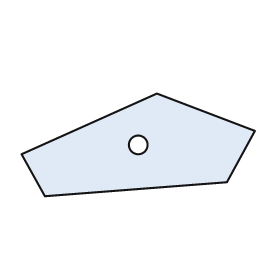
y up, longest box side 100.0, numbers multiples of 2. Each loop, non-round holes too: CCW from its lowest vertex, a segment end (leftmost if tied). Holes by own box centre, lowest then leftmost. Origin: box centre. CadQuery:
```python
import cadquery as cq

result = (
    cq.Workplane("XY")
    .moveTo(-40.0, -22.0)
    .lineTo(38.0, -16.0)
    .lineTo(50.0, 6.0)
    .lineTo(8.0, 22.0)
    .lineTo(-50.0, -4.0)
    .close()
    .moveTo(0.0, 0.0)
    .circle(4.0)
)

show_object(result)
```